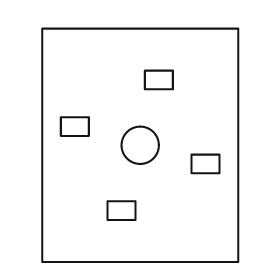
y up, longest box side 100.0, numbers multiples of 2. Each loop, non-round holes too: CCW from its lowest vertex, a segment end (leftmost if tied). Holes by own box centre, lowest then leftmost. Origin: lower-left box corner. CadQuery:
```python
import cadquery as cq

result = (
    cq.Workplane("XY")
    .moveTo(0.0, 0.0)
    .lineTo(84.0, 0.0)
    .lineTo(84.0, 100.0)
    .lineTo(0.0, 100.0)
    .close()
    .moveTo(28.0, 18.0)
    .lineTo(40.0, 18.0)
    .lineTo(40.0, 26.0)
    .lineTo(28.0, 26.0)
    .close()
    .moveTo(64.0, 38.0)
    .lineTo(76.0, 38.0)
    .lineTo(76.0, 46.0)
    .lineTo(64.0, 46.0)
    .close()
    .moveTo(42.0, 50.0)
    .circle(8.0)
    .moveTo(8.0, 54.0)
    .lineTo(20.0, 54.0)
    .lineTo(20.0, 62.0)
    .lineTo(8.0, 62.0)
    .close()
    .moveTo(44.0, 74.0)
    .lineTo(56.0, 74.0)
    .lineTo(56.0, 82.0)
    .lineTo(44.0, 82.0)
    .close()
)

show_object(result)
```